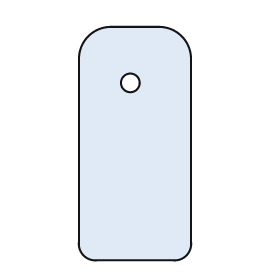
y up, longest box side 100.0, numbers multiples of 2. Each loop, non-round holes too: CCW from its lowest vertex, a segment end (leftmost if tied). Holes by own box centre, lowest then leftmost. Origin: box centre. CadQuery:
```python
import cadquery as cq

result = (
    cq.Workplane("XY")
    .moveTo(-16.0, -50.0)
    .lineTo(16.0, -50.0)
    .threePointArc((22.0, -48.0), (24.0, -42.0))
    .lineTo(24.0, 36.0)
    .threePointArc((20.0, 46.0), (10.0, 50.0))
    .lineTo(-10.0, 50.0)
    .threePointArc((-20.0, 46.0), (-24.0, 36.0))
    .lineTo(-24.0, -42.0)
    .threePointArc((-22.0, -48.0), (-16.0, -50.0))
    .close()
    .moveTo(-2.0, 26.0)
    .circle(4.0)
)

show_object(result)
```